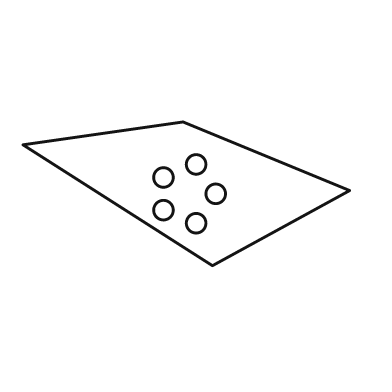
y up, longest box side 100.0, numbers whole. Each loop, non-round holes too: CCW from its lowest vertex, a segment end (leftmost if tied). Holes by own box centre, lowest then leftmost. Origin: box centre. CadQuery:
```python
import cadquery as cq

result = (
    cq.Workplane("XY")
    .moveTo(8.0, -22.0)
    .lineTo(50.0, 1.0)
    .lineTo(-1.0, 22.0)
    .lineTo(-50.0, 15.0)
    .close()
    .moveTo(3.0, -9.0)
    .circle(3.0)
    .moveTo(-7.0, -5.0)
    .circle(3.0)
    .moveTo(9.0, 0.0)
    .circle(3.0)
    .moveTo(-7.0, 5.0)
    .circle(3.0)
    .moveTo(3.0, 9.0)
    .circle(3.0)
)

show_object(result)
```